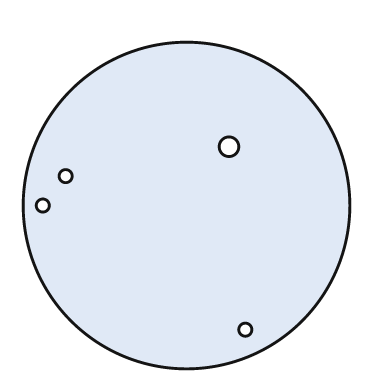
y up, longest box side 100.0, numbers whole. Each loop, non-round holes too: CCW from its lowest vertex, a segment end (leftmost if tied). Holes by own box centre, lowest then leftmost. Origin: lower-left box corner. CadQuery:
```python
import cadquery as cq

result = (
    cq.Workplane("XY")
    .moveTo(50.0, 50.0)
    .circle(50.0)
    .moveTo(68.0, 12.0)
    .circle(2.0)
    .moveTo(6.0, 50.0)
    .circle(2.0)
    .moveTo(13.0, 59.0)
    .circle(2.0)
    .moveTo(63.0, 68.0)
    .circle(3.0)
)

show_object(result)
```